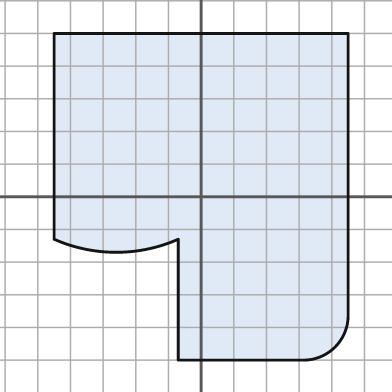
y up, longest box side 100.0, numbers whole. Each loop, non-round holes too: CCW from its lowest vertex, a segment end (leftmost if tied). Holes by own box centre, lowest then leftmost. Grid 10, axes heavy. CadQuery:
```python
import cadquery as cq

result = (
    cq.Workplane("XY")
    .moveTo(-7.0, -50.0)
    .lineTo(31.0, -50.0)
    .threePointArc((41.0, -46.0), (45.0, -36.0))
    .lineTo(45.0, 50.0)
    .lineTo(-45.0, 50.0)
    .lineTo(-45.0, -13.0)
    .threePointArc((-26.0, -17.0), (-7.0, -13.0))
    .close()
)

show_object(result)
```